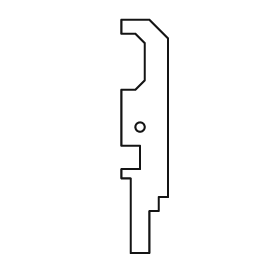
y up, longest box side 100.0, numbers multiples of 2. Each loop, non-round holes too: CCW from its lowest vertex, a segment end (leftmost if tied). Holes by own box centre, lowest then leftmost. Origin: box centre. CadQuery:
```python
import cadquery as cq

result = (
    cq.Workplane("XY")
    .moveTo(-6.0, -50.0)
    .lineTo(2.0, -50.0)
    .lineTo(2.0, -32.0)
    .lineTo(6.0, -32.0)
    .lineTo(6.0, -26.0)
    .lineTo(10.0, -26.0)
    .lineTo(10.0, 42.0)
    .lineTo(2.0, 50.0)
    .lineTo(-10.0, 50.0)
    .lineTo(-10.0, 44.0)
    .lineTo(-4.0, 44.0)
    .lineTo(0.0, 40.0)
    .lineTo(0.0, 24.0)
    .lineTo(-4.0, 20.0)
    .lineTo(-10.0, 20.0)
    .lineTo(-10.0, -4.0)
    .lineTo(-2.0, -4.0)
    .lineTo(-2.0, -14.0)
    .lineTo(-10.0, -14.0)
    .lineTo(-10.0, -18.0)
    .lineTo(-6.0, -18.0)
    .close()
    .moveTo(-2.0, 4.0)
    .circle(2.0)
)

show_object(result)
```